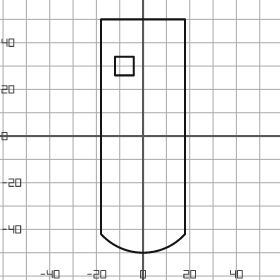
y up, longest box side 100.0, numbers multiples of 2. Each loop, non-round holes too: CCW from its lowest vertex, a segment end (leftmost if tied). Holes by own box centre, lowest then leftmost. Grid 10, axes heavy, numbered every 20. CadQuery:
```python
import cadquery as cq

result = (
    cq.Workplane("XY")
    .moveTo(-18.0, -42.0)
    .threePointArc((0.0, -50.0), (18.0, -42.0))
    .lineTo(18.0, 50.0)
    .lineTo(-18.0, 50.0)
    .close()
    .moveTo(-12.0, 26.0)
    .lineTo(-4.0, 26.0)
    .lineTo(-4.0, 34.0)
    .lineTo(-12.0, 34.0)
    .close()
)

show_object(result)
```